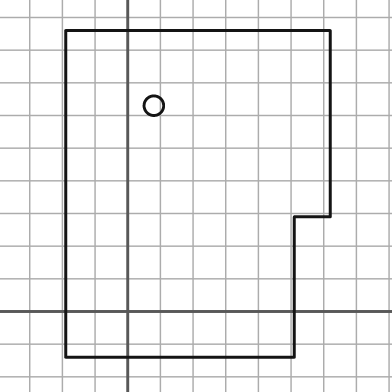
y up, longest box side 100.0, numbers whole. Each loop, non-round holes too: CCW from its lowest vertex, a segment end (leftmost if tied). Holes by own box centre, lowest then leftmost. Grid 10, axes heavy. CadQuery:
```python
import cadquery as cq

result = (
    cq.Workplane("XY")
    .moveTo(-19.0, -14.0)
    .lineTo(51.0, -14.0)
    .lineTo(51.0, 29.0)
    .lineTo(62.0, 29.0)
    .lineTo(62.0, 86.0)
    .lineTo(-19.0, 86.0)
    .close()
    .moveTo(8.0, 63.0)
    .circle(3.0)
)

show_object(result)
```